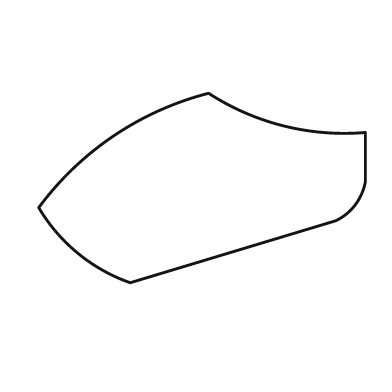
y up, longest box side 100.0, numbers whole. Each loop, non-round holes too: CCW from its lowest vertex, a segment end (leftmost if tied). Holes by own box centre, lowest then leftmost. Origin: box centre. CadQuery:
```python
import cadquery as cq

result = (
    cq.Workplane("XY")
    .moveTo(-22.0, -29.0)
    .lineTo(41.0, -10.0)
    .threePointArc((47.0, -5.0), (50.0, 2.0))
    .lineTo(50.0, 17.0)
    .threePointArc((25.0, 19.0), (2.0, 29.0))
    .threePointArc((-27.0, 16.0), (-50.0, -6.0))
    .threePointArc((-38.0, -20.0), (-22.0, -29.0))
    .close()
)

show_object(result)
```